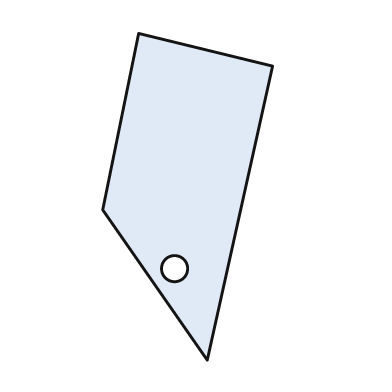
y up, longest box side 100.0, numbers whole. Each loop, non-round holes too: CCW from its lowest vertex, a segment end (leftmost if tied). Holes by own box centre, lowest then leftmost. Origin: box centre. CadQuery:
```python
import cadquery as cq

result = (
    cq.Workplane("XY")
    .moveTo(6.0, -50.0)
    .lineTo(26.0, 40.0)
    .lineTo(-15.0, 50.0)
    .lineTo(-26.0, -4.0)
    .close()
    .moveTo(-4.0, -22.0)
    .circle(4.0)
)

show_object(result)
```